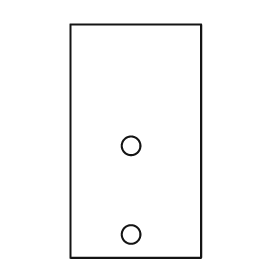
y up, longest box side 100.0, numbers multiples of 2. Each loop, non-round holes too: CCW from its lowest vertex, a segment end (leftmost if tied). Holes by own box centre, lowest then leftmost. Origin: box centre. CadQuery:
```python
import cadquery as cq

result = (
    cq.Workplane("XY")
    .moveTo(-28.0, -50.0)
    .lineTo(28.0, -50.0)
    .lineTo(28.0, 50.0)
    .lineTo(-28.0, 50.0)
    .close()
    .moveTo(-2.0, -40.0)
    .circle(4.0)
    .moveTo(-2.0, -2.0)
    .circle(4.0)
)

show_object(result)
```